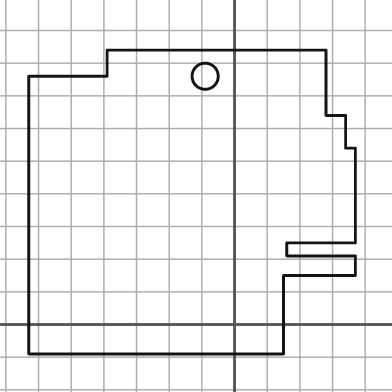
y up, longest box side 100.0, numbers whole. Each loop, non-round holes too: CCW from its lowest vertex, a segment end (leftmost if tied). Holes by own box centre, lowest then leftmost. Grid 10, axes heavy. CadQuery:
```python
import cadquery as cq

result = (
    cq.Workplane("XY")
    .moveTo(-63.0, -9.0)
    .lineTo(15.0, -9.0)
    .lineTo(15.0, 15.0)
    .lineTo(37.0, 15.0)
    .lineTo(37.0, 21.0)
    .lineTo(16.0, 21.0)
    .lineTo(16.0, 25.0)
    .lineTo(37.0, 25.0)
    .lineTo(37.0, 54.0)
    .lineTo(34.0, 54.0)
    .lineTo(34.0, 64.0)
    .lineTo(28.0, 64.0)
    .lineTo(28.0, 84.0)
    .lineTo(-39.0, 84.0)
    .lineTo(-39.0, 76.0)
    .lineTo(-63.0, 76.0)
    .close()
    .moveTo(-9.0, 76.0)
    .circle(4.0)
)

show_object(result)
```